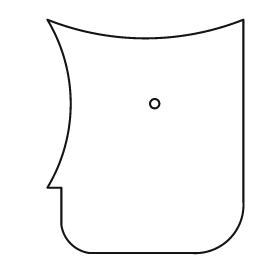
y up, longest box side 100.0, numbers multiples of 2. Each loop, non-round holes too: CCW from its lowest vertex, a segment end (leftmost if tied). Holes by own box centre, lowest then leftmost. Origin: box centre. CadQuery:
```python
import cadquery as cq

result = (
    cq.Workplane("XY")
    .moveTo(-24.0, -50.0)
    .lineTo(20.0, -50.0)
    .threePointArc((36.0, -44.0), (42.0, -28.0))
    .lineTo(42.0, 50.0)
    .threePointArc((0.0, 42.0), (-42.0, 50.0))
    .threePointArc((-32.0, 14.0), (-42.0, -22.0))
    .lineTo(-36.0, -22.0)
    .lineTo(-36.0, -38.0)
    .threePointArc((-32.0, -46.0), (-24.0, -50.0))
    .close()
    .moveTo(4.0, 14.0)
    .circle(2.0)
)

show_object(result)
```